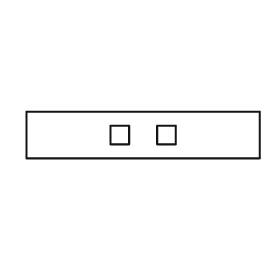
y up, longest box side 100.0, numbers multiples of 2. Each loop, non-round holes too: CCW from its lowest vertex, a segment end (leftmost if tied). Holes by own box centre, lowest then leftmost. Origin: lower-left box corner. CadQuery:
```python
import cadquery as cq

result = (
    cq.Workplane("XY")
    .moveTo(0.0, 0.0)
    .lineTo(100.0, 0.0)
    .lineTo(100.0, 20.0)
    .lineTo(0.0, 20.0)
    .close()
    .moveTo(36.0, 6.0)
    .lineTo(44.0, 6.0)
    .lineTo(44.0, 14.0)
    .lineTo(36.0, 14.0)
    .close()
    .moveTo(56.0, 6.0)
    .lineTo(64.0, 6.0)
    .lineTo(64.0, 14.0)
    .lineTo(56.0, 14.0)
    .close()
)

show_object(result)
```